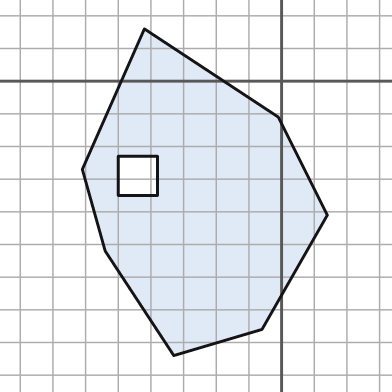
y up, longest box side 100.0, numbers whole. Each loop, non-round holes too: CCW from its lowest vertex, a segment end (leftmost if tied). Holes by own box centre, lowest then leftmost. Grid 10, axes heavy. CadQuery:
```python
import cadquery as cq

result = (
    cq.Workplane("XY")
    .moveTo(-33.0, -84.0)
    .lineTo(-6.0, -76.0)
    .lineTo(14.0, -41.0)
    .lineTo(-1.0, -11.0)
    .lineTo(-42.0, 16.0)
    .lineTo(-61.0, -27.0)
    .lineTo(-54.0, -52.0)
    .close()
    .moveTo(-50.0, -35.0)
    .lineTo(-38.0, -35.0)
    .lineTo(-38.0, -23.0)
    .lineTo(-50.0, -23.0)
    .close()
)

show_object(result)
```